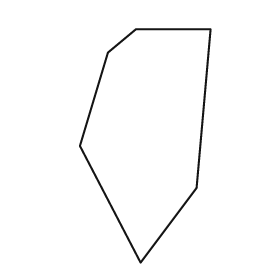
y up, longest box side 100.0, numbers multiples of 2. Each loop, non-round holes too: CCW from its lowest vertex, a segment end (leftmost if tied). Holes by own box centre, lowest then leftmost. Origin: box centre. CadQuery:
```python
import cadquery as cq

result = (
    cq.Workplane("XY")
    .moveTo(-2.0, -50.0)
    .lineTo(22.0, -18.0)
    .lineTo(28.0, 50.0)
    .lineTo(-4.0, 50.0)
    .lineTo(-16.0, 40.0)
    .lineTo(-28.0, 0.0)
    .close()
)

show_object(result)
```